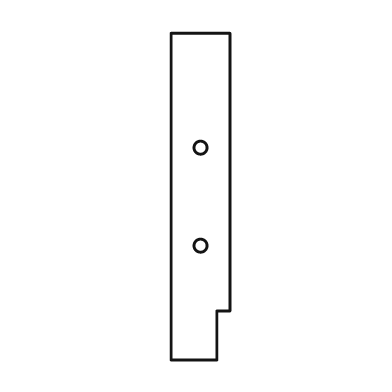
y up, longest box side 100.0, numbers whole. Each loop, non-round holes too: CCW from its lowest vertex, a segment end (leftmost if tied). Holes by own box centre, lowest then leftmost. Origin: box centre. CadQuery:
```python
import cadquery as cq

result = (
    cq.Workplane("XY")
    .moveTo(-9.0, -50.0)
    .lineTo(5.0, -50.0)
    .lineTo(5.0, -35.0)
    .lineTo(9.0, -35.0)
    .lineTo(9.0, 50.0)
    .lineTo(-9.0, 50.0)
    .close()
    .moveTo(0.0, -15.0)
    .circle(2.0)
    .moveTo(0.0, 15.0)
    .circle(2.0)
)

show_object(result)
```